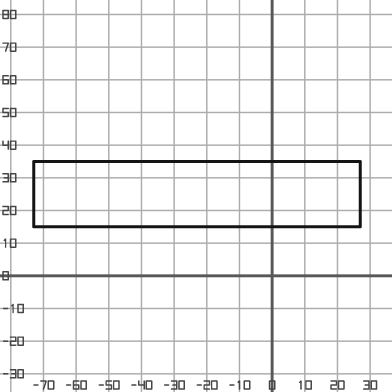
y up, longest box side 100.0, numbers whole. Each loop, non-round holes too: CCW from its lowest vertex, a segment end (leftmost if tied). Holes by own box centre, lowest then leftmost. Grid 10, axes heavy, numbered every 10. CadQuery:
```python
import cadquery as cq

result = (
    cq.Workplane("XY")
    .moveTo(-73.0, 15.0)
    .lineTo(27.0, 15.0)
    .lineTo(27.0, 35.0)
    .lineTo(-73.0, 35.0)
    .close()
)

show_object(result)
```